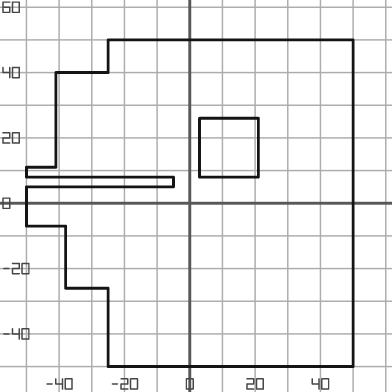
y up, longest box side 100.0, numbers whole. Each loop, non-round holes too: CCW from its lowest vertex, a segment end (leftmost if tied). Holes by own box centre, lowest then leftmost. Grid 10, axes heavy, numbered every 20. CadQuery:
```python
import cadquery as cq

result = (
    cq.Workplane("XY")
    .moveTo(-25.0, -50.0)
    .lineTo(50.0, -50.0)
    .lineTo(50.0, 50.0)
    .lineTo(-25.0, 50.0)
    .lineTo(-25.0, 40.0)
    .lineTo(-41.0, 40.0)
    .lineTo(-41.0, 11.0)
    .lineTo(-50.0, 11.0)
    .lineTo(-50.0, 8.0)
    .lineTo(-5.0, 8.0)
    .lineTo(-5.0, 5.0)
    .lineTo(-50.0, 5.0)
    .lineTo(-50.0, -7.0)
    .lineTo(-38.0, -7.0)
    .lineTo(-38.0, -26.0)
    .lineTo(-25.0, -26.0)
    .close()
    .moveTo(3.0, 8.0)
    .lineTo(21.0, 8.0)
    .lineTo(21.0, 26.0)
    .lineTo(3.0, 26.0)
    .close()
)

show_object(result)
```